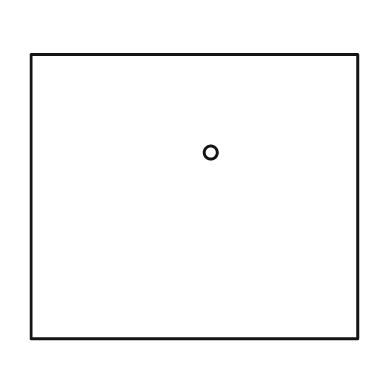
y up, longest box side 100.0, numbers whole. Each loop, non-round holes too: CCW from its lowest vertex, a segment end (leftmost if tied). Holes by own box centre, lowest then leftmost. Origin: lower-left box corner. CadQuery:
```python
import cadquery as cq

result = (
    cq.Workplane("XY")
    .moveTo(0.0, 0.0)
    .lineTo(100.0, 0.0)
    .lineTo(100.0, 87.0)
    .lineTo(0.0, 87.0)
    .close()
    .moveTo(55.0, 57.0)
    .circle(2.0)
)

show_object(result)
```